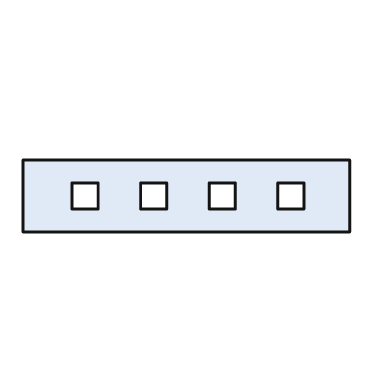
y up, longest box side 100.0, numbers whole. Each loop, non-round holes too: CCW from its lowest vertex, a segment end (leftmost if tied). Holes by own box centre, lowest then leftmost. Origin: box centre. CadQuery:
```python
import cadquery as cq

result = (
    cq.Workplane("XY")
    .moveTo(-50.0, -11.0)
    .lineTo(50.0, -11.0)
    .lineTo(50.0, 11.0)
    .lineTo(-50.0, 11.0)
    .close()
    .moveTo(-35.0, -4.0)
    .lineTo(-27.0, -4.0)
    .lineTo(-27.0, 4.0)
    .lineTo(-35.0, 4.0)
    .close()
    .moveTo(-14.0, -4.0)
    .lineTo(-6.0, -4.0)
    .lineTo(-6.0, 4.0)
    .lineTo(-14.0, 4.0)
    .close()
    .moveTo(7.0, -4.0)
    .lineTo(15.0, -4.0)
    .lineTo(15.0, 4.0)
    .lineTo(7.0, 4.0)
    .close()
    .moveTo(28.0, -4.0)
    .lineTo(36.0, -4.0)
    .lineTo(36.0, 4.0)
    .lineTo(28.0, 4.0)
    .close()
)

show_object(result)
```